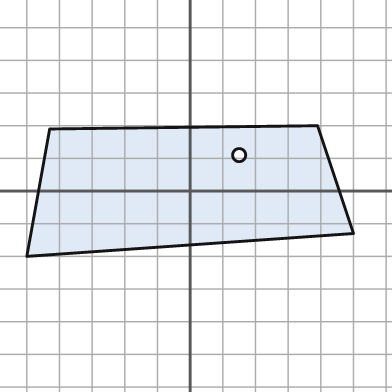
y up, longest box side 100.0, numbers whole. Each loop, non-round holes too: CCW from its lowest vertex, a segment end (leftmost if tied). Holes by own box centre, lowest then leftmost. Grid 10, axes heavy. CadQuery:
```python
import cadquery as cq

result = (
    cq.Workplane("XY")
    .moveTo(-50.0, -20.0)
    .lineTo(50.0, -13.0)
    .lineTo(39.0, 20.0)
    .lineTo(-43.0, 19.0)
    .close()
    .moveTo(15.0, 11.0)
    .circle(2.0)
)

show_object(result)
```